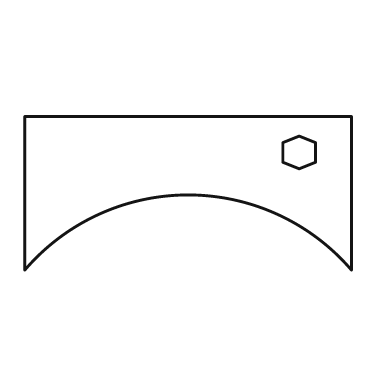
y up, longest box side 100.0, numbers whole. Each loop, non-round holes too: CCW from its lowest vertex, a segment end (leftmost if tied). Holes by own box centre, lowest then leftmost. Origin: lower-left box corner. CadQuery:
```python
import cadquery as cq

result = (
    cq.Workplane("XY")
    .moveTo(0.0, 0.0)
    .threePointArc((50.0, 23.0), (100.0, 0.0))
    .lineTo(100.0, 47.0)
    .lineTo(0.0, 47.0)
    .close()
    .moveTo(84.0, 31.0)
    .lineTo(89.0, 33.0)
    .lineTo(89.0, 39.0)
    .lineTo(84.0, 41.0)
    .lineTo(79.0, 39.0)
    .lineTo(79.0, 33.0)
    .close()
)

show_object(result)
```